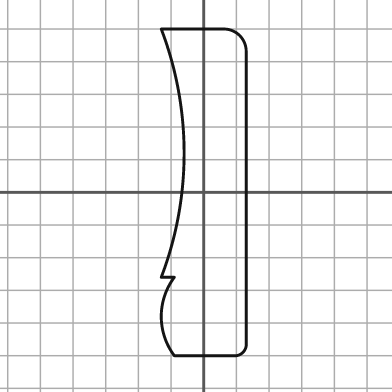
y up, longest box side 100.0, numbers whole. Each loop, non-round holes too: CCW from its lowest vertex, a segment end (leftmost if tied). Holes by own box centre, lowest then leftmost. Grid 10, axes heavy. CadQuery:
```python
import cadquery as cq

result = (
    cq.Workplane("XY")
    .moveTo(-9.0, -50.0)
    .lineTo(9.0, -50.0)
    .threePointArc((12.0, -49.0), (13.0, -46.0))
    .lineTo(13.0, 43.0)
    .threePointArc((11.0, 48.0), (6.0, 50.0))
    .lineTo(-13.0, 50.0)
    .threePointArc((-6.0, 12.0), (-13.0, -26.0))
    .lineTo(-9.0, -26.0)
    .threePointArc((-13.0, -38.0), (-9.0, -50.0))
    .close()
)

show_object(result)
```